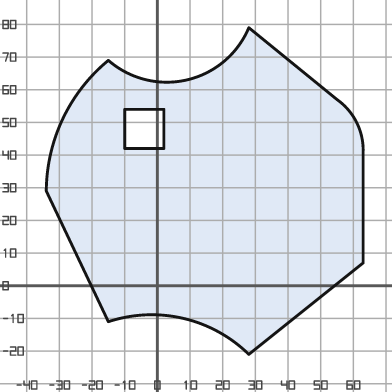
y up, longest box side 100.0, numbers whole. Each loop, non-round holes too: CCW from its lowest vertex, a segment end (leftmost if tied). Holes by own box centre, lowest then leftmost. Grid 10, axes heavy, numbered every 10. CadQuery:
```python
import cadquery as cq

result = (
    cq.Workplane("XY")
    .moveTo(28.0, -21.0)
    .lineTo(63.0, 7.0)
    .lineTo(63.0, 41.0)
    .threePointArc((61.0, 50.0), (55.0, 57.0))
    .lineTo(28.0, 79.0)
    .threePointArc((9.0, 63.0), (-15.0, 69.0))
    .threePointArc((-29.0, 51.0), (-34.0, 29.0))
    .lineTo(-15.0, -11.0)
    .threePointArc((8.0, -10.0), (28.0, -21.0))
    .close()
    .moveTo(-10.0, 42.0)
    .lineTo(2.0, 42.0)
    .lineTo(2.0, 54.0)
    .lineTo(-10.0, 54.0)
    .close()
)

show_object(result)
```